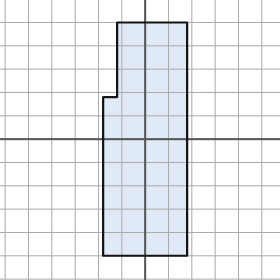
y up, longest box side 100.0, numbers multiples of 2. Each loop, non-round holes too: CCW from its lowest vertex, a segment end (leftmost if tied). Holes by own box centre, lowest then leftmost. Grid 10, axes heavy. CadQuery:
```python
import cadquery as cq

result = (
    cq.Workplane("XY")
    .moveTo(-18.0, -50.0)
    .lineTo(18.0, -50.0)
    .lineTo(18.0, 50.0)
    .lineTo(-12.0, 50.0)
    .lineTo(-12.0, 18.0)
    .lineTo(-18.0, 18.0)
    .close()
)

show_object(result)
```